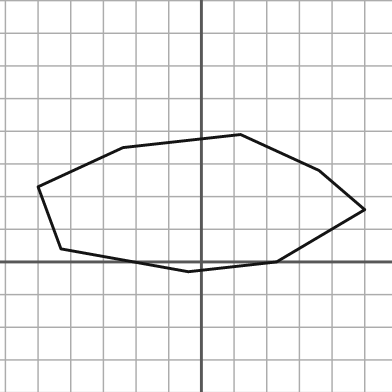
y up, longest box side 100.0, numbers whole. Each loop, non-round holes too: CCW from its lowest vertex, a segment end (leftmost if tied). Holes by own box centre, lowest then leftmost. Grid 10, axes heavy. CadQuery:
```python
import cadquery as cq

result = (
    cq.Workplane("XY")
    .moveTo(-4.0, -3.0)
    .lineTo(23.0, 0.0)
    .lineTo(50.0, 16.0)
    .lineTo(36.0, 28.0)
    .lineTo(12.0, 39.0)
    .lineTo(-24.0, 35.0)
    .lineTo(-50.0, 23.0)
    .lineTo(-43.0, 4.0)
    .close()
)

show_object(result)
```